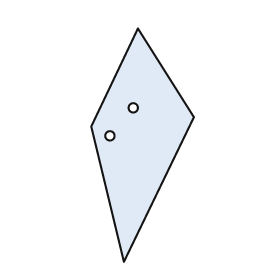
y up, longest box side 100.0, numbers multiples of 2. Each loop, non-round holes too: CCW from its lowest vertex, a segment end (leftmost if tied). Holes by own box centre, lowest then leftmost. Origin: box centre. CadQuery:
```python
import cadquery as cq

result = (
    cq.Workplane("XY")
    .moveTo(-8.0, -50.0)
    .lineTo(22.0, 12.0)
    .lineTo(-2.0, 50.0)
    .lineTo(-22.0, 8.0)
    .close()
    .moveTo(-14.0, 4.0)
    .circle(2.0)
    .moveTo(-4.0, 16.0)
    .circle(2.0)
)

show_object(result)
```